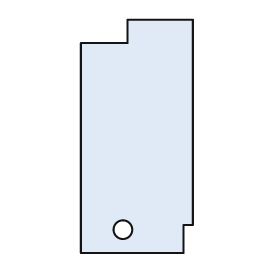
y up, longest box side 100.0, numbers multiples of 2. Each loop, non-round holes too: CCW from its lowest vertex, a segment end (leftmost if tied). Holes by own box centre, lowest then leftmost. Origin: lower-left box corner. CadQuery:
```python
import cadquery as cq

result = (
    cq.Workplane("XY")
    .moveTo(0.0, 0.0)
    .lineTo(44.0, 0.0)
    .lineTo(44.0, 12.0)
    .lineTo(48.0, 12.0)
    .lineTo(48.0, 100.0)
    .lineTo(20.0, 100.0)
    .lineTo(20.0, 90.0)
    .lineTo(0.0, 90.0)
    .close()
    .moveTo(18.0, 10.0)
    .circle(4.0)
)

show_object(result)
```